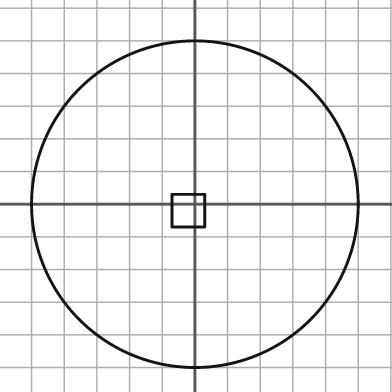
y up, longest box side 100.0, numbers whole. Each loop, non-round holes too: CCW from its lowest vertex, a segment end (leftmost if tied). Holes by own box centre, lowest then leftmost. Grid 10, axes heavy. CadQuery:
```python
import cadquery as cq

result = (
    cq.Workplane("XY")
    .moveTo(0.0, 0.0)
    .circle(50.0)
    .moveTo(-7.0, -7.0)
    .lineTo(3.0, -7.0)
    .lineTo(3.0, 3.0)
    .lineTo(-7.0, 3.0)
    .close()
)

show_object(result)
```